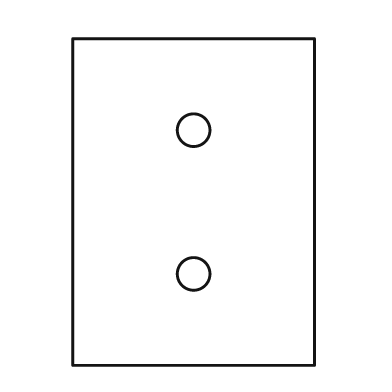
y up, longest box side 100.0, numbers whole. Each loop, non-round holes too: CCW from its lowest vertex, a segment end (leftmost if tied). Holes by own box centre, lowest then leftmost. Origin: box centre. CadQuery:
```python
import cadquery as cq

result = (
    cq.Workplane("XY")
    .moveTo(-37.0, -50.0)
    .lineTo(37.0, -50.0)
    .lineTo(37.0, 50.0)
    .lineTo(-37.0, 50.0)
    .close()
    .moveTo(0.0, -22.0)
    .circle(5.0)
    .moveTo(0.0, 22.0)
    .circle(5.0)
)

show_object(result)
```